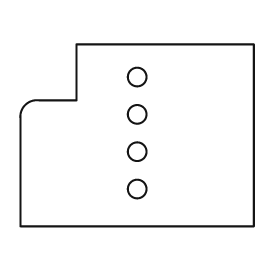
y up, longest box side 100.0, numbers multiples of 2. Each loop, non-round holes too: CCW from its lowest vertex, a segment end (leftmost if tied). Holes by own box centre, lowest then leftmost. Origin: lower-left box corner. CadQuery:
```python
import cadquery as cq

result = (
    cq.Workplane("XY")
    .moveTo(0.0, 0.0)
    .lineTo(100.0, 0.0)
    .lineTo(100.0, 78.0)
    .lineTo(24.0, 78.0)
    .lineTo(24.0, 54.0)
    .lineTo(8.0, 54.0)
    .threePointArc((2.0, 52.0), (0.0, 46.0))
    .close()
    .moveTo(50.0, 16.0)
    .circle(4.0)
    .moveTo(50.0, 32.0)
    .circle(4.0)
    .moveTo(50.0, 48.0)
    .circle(4.0)
    .moveTo(50.0, 64.0)
    .circle(4.0)
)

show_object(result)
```